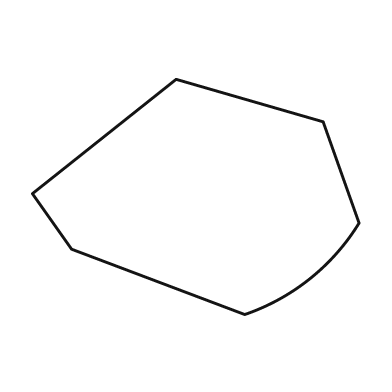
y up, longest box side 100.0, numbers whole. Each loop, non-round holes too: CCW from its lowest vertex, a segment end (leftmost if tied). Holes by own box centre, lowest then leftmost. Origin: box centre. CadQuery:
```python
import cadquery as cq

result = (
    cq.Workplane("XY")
    .moveTo(15.0, -36.0)
    .threePointArc((35.0, -25.0), (50.0, -8.0))
    .lineTo(39.0, 23.0)
    .lineTo(-6.0, 36.0)
    .lineTo(-50.0, 1.0)
    .lineTo(-38.0, -16.0)
    .close()
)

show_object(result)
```